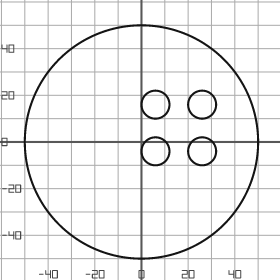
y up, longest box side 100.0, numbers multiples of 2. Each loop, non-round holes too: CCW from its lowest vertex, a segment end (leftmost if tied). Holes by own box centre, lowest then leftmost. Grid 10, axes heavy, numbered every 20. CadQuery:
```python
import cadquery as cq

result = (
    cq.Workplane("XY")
    .moveTo(0.0, 0.0)
    .circle(50.0)
    .moveTo(6.0, -4.0)
    .circle(6.0)
    .moveTo(26.0, -4.0)
    .circle(6.0)
    .moveTo(6.0, 16.0)
    .circle(6.0)
    .moveTo(26.0, 16.0)
    .circle(6.0)
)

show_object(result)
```